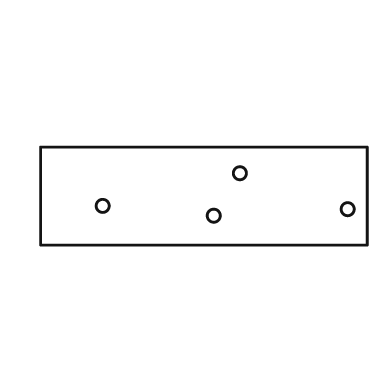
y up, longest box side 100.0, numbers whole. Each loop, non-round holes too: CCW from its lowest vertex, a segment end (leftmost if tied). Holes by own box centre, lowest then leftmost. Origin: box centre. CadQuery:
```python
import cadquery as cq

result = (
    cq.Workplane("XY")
    .moveTo(-50.0, -15.0)
    .lineTo(50.0, -15.0)
    .lineTo(50.0, 15.0)
    .lineTo(-50.0, 15.0)
    .close()
    .moveTo(3.0, -6.0)
    .circle(2.0)
    .moveTo(44.0, -4.0)
    .circle(2.0)
    .moveTo(-31.0, -3.0)
    .circle(2.0)
    .moveTo(11.0, 7.0)
    .circle(2.0)
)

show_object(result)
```